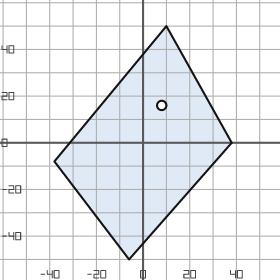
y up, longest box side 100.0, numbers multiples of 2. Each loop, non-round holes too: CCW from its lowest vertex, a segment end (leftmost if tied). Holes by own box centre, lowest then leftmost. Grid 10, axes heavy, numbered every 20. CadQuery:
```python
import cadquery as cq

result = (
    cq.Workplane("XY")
    .moveTo(-6.0, -50.0)
    .lineTo(38.0, 0.0)
    .lineTo(10.0, 50.0)
    .lineTo(-38.0, -8.0)
    .close()
    .moveTo(8.0, 16.0)
    .circle(2.0)
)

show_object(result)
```